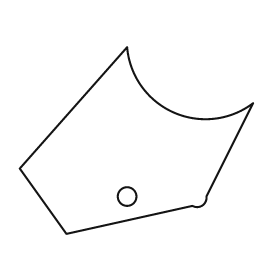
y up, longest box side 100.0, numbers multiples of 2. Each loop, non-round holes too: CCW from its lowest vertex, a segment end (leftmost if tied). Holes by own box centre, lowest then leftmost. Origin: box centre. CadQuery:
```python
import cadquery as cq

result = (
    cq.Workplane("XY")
    .moveTo(-30.0, -40.0)
    .lineTo(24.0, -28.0)
    .threePointArc((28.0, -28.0), (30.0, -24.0))
    .lineTo(50.0, 16.0)
    .threePointArc((16.0, 12.0), (-4.0, 40.0))
    .lineTo(-50.0, -12.0)
    .close()
    .moveTo(-4.0, -24.0)
    .circle(4.0)
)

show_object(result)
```